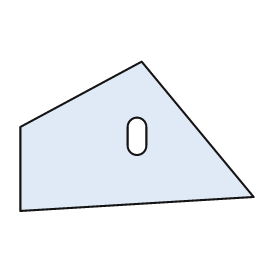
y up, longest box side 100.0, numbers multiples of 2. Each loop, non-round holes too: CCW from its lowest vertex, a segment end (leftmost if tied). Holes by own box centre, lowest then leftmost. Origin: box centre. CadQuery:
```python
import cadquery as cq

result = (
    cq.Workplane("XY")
    .moveTo(-50.0, -32.0)
    .lineTo(50.0, -26.0)
    .lineTo(2.0, 32.0)
    .lineTo(-50.0, 4.0)
    .close()
    .moveTo(-4.0, -4.0)
    .threePointArc((0.0, -8.0), (4.0, -4.0))
    .lineTo(4.0, 4.0)
    .threePointArc((0.0, 8.0), (-4.0, 4.0))
    .close()
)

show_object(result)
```